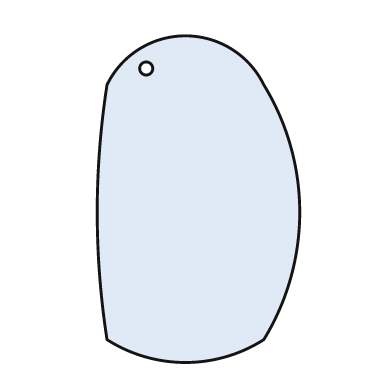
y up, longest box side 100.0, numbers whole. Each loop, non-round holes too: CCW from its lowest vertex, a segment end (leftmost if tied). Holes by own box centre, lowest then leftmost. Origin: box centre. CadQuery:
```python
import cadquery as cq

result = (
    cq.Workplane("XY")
    .moveTo(-28.0, -43.0)
    .threePointArc((-4.0, -50.0), (20.0, -43.0))
    .threePointArc((31.0, -4.0), (20.0, 35.0))
    .threePointArc((-4.0, 50.0), (-28.0, 35.0))
    .threePointArc((-31.0, -4.0), (-28.0, -43.0))
    .close()
    .moveTo(-16.0, 40.0)
    .circle(2.0)
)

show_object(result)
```